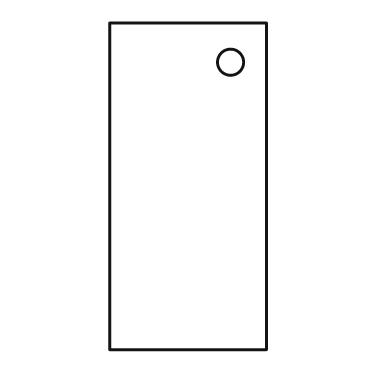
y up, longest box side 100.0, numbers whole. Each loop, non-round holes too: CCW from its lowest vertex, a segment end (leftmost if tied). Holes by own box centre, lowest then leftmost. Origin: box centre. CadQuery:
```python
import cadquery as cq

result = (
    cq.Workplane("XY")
    .moveTo(-24.0, -50.0)
    .lineTo(24.0, -50.0)
    .lineTo(24.0, 50.0)
    .lineTo(-24.0, 50.0)
    .close()
    .moveTo(13.0, 38.0)
    .circle(4.0)
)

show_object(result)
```